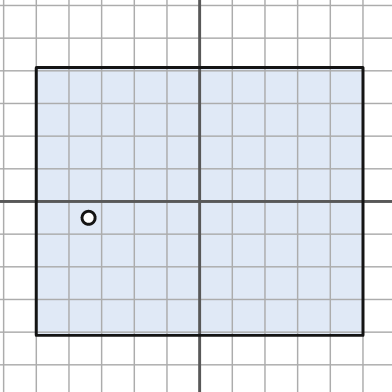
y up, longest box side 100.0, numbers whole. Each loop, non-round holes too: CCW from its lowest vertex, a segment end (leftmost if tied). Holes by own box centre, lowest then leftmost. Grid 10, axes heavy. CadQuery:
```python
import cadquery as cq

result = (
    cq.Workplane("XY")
    .moveTo(-50.0, -41.0)
    .lineTo(50.0, -41.0)
    .lineTo(50.0, 41.0)
    .lineTo(-50.0, 41.0)
    .close()
    .moveTo(-34.0, -5.0)
    .circle(2.0)
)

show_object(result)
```